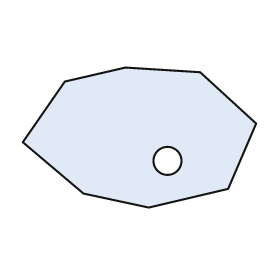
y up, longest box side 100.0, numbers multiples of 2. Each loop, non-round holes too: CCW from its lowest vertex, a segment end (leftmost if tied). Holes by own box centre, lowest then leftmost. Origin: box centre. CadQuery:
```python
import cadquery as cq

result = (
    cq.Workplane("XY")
    .moveTo(4.0, -30.0)
    .lineTo(38.0, -22.0)
    .lineTo(50.0, 6.0)
    .lineTo(26.0, 28.0)
    .lineTo(-6.0, 30.0)
    .lineTo(-32.0, 24.0)
    .lineTo(-50.0, -2.0)
    .lineTo(-24.0, -24.0)
    .close()
    .moveTo(12.0, -10.0)
    .circle(6.0)
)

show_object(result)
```